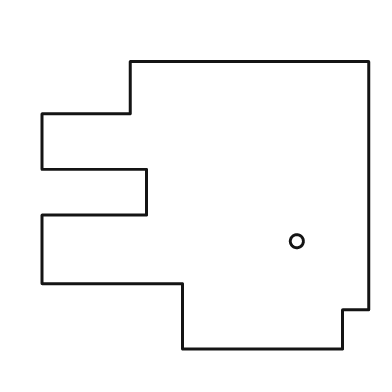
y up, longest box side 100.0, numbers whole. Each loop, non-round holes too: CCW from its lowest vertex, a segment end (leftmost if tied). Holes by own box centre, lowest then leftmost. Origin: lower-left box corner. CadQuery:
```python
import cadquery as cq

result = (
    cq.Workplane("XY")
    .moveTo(43.0, 0.0)
    .lineTo(92.0, 0.0)
    .lineTo(92.0, 12.0)
    .lineTo(100.0, 12.0)
    .lineTo(100.0, 88.0)
    .lineTo(27.0, 88.0)
    .lineTo(27.0, 72.0)
    .lineTo(0.0, 72.0)
    .lineTo(0.0, 55.0)
    .lineTo(32.0, 55.0)
    .lineTo(32.0, 41.0)
    .lineTo(0.0, 41.0)
    .lineTo(0.0, 20.0)
    .lineTo(43.0, 20.0)
    .close()
    .moveTo(78.0, 33.0)
    .circle(2.0)
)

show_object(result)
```